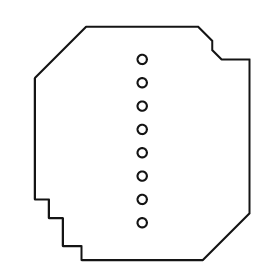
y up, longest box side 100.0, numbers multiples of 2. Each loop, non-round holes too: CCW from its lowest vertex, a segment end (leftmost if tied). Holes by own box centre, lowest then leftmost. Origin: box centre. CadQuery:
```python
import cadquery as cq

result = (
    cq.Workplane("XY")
    .moveTo(-26.0, -50.0)
    .lineTo(26.0, -50.0)
    .lineTo(46.0, -30.0)
    .lineTo(46.0, 36.0)
    .lineTo(34.0, 36.0)
    .lineTo(30.0, 40.0)
    .lineTo(30.0, 44.0)
    .lineTo(24.0, 50.0)
    .lineTo(-24.0, 50.0)
    .lineTo(-46.0, 28.0)
    .lineTo(-46.0, -24.0)
    .lineTo(-40.0, -24.0)
    .lineTo(-40.0, -32.0)
    .lineTo(-34.0, -32.0)
    .lineTo(-34.0, -44.0)
    .lineTo(-26.0, -44.0)
    .close()
    .moveTo(0.0, -34.0)
    .circle(2.0)
    .moveTo(0.0, -24.0)
    .circle(2.0)
    .moveTo(0.0, -14.0)
    .circle(2.0)
    .moveTo(0.0, -4.0)
    .circle(2.0)
    .moveTo(0.0, 6.0)
    .circle(2.0)
    .moveTo(0.0, 16.0)
    .circle(2.0)
    .moveTo(0.0, 26.0)
    .circle(2.0)
    .moveTo(0.0, 36.0)
    .circle(2.0)
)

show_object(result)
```